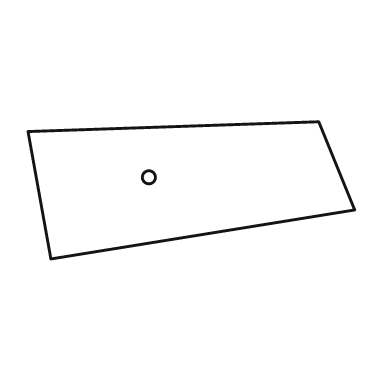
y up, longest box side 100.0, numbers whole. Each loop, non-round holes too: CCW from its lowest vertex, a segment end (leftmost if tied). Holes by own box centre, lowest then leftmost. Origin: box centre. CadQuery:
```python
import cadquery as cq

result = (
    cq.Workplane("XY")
    .moveTo(-43.0, -21.0)
    .lineTo(50.0, -6.0)
    .lineTo(39.0, 21.0)
    .lineTo(-50.0, 18.0)
    .close()
    .moveTo(-13.0, 4.0)
    .circle(2.0)
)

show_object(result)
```